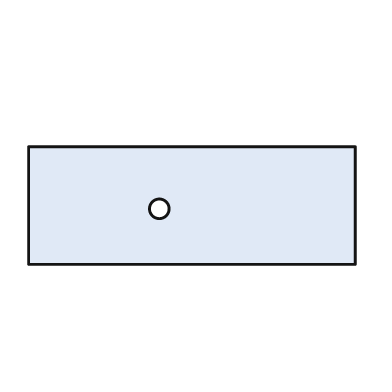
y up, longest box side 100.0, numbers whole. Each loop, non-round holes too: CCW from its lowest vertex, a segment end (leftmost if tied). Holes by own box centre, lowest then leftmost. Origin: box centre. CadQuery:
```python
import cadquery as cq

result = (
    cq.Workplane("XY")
    .moveTo(-50.0, -18.0)
    .lineTo(50.0, -18.0)
    .lineTo(50.0, 18.0)
    .lineTo(-50.0, 18.0)
    .close()
    .moveTo(-10.0, -1.0)
    .circle(3.0)
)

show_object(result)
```